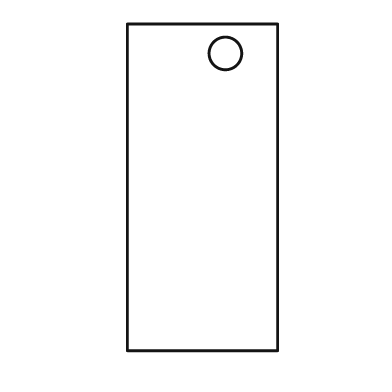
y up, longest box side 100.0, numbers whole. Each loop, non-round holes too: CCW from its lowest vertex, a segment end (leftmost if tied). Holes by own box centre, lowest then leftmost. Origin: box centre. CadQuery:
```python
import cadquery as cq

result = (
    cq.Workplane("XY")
    .moveTo(-23.0, -50.0)
    .lineTo(23.0, -50.0)
    .lineTo(23.0, 50.0)
    .lineTo(-23.0, 50.0)
    .close()
    .moveTo(7.0, 41.0)
    .circle(5.0)
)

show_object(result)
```